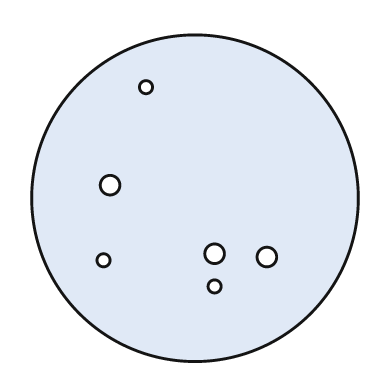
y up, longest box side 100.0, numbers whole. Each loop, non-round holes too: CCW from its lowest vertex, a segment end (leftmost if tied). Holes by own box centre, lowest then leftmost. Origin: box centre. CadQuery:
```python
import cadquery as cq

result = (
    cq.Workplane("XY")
    .moveTo(0.0, 0.0)
    .circle(50.0)
    .moveTo(6.0, -27.0)
    .circle(2.0)
    .moveTo(-28.0, -19.0)
    .circle(2.0)
    .moveTo(22.0, -18.0)
    .circle(3.0)
    .moveTo(6.0, -17.0)
    .circle(3.0)
    .moveTo(-26.0, 4.0)
    .circle(3.0)
    .moveTo(-15.0, 34.0)
    .circle(2.0)
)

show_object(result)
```